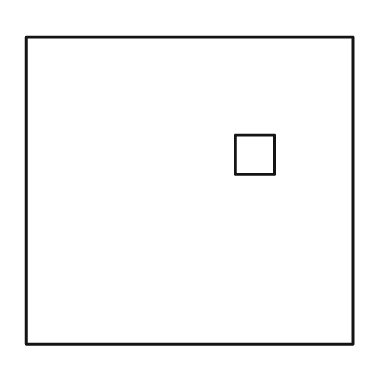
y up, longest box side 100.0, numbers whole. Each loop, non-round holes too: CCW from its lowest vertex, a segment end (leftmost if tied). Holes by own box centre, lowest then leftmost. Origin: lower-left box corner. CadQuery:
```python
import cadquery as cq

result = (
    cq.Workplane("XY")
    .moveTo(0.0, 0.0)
    .lineTo(100.0, 0.0)
    .lineTo(100.0, 94.0)
    .lineTo(0.0, 94.0)
    .close()
    .moveTo(64.0, 52.0)
    .lineTo(76.0, 52.0)
    .lineTo(76.0, 64.0)
    .lineTo(64.0, 64.0)
    .close()
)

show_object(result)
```